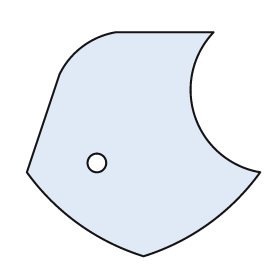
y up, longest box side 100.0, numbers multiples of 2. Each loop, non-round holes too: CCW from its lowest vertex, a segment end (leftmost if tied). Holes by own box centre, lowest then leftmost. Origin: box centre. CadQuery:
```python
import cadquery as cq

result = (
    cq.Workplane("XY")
    .moveTo(0.0, -48.0)
    .threePointArc((28.0, -34.0), (50.0, -12.0))
    .threePointArc((22.0, 12.0), (30.0, 48.0))
    .lineTo(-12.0, 48.0)
    .threePointArc((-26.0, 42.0), (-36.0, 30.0))
    .lineTo(-50.0, -12.0)
    .threePointArc((-28.0, -34.0), (0.0, -48.0))
    .close()
    .moveTo(-20.0, -8.0)
    .circle(4.0)
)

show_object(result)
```